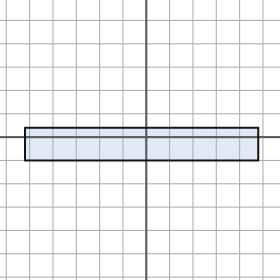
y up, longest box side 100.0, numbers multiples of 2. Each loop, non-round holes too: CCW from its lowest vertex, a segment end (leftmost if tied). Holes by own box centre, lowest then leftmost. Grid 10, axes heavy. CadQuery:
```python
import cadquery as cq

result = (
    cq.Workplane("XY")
    .moveTo(-52.0, -10.0)
    .lineTo(48.0, -10.0)
    .lineTo(48.0, 4.0)
    .lineTo(-52.0, 4.0)
    .close()
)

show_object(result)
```